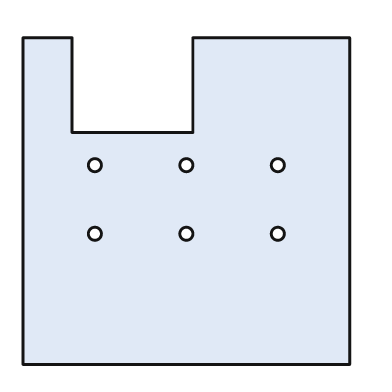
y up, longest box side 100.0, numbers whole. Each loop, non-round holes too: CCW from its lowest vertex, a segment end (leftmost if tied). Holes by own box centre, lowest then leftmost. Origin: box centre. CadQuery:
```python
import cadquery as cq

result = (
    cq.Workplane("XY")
    .moveTo(-50.0, -50.0)
    .lineTo(50.0, -50.0)
    .lineTo(50.0, 50.0)
    .lineTo(2.0, 50.0)
    .lineTo(2.0, 21.0)
    .lineTo(-35.0, 21.0)
    .lineTo(-35.0, 50.0)
    .lineTo(-50.0, 50.0)
    .close()
    .moveTo(-28.0, -10.0)
    .circle(2.0)
    .moveTo(0.0, -10.0)
    .circle(2.0)
    .moveTo(28.0, -10.0)
    .circle(2.0)
    .moveTo(-28.0, 11.0)
    .circle(2.0)
    .moveTo(0.0, 11.0)
    .circle(2.0)
    .moveTo(28.0, 11.0)
    .circle(2.0)
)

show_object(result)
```